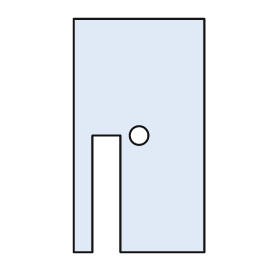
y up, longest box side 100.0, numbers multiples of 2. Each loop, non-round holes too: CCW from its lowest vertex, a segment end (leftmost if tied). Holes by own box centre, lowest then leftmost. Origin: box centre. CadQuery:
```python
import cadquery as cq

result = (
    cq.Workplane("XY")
    .moveTo(-28.0, -50.0)
    .lineTo(-20.0, -50.0)
    .lineTo(-20.0, 0.0)
    .lineTo(-8.0, 0.0)
    .lineTo(-8.0, -50.0)
    .lineTo(28.0, -50.0)
    .lineTo(28.0, 50.0)
    .lineTo(-28.0, 50.0)
    .close()
    .moveTo(0.0, 0.0)
    .circle(4.0)
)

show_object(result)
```